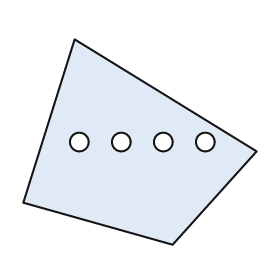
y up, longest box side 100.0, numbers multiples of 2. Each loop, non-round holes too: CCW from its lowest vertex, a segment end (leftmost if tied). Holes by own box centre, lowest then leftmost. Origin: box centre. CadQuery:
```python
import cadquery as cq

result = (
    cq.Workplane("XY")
    .moveTo(14.0, -44.0)
    .lineTo(50.0, -4.0)
    .lineTo(-28.0, 44.0)
    .lineTo(-50.0, -26.0)
    .close()
    .moveTo(-26.0, 0.0)
    .circle(4.0)
    .moveTo(-8.0, 0.0)
    .circle(4.0)
    .moveTo(10.0, 0.0)
    .circle(4.0)
    .moveTo(28.0, 0.0)
    .circle(4.0)
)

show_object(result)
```